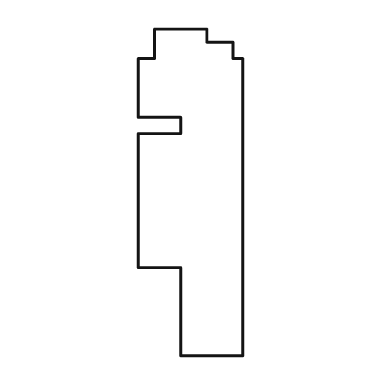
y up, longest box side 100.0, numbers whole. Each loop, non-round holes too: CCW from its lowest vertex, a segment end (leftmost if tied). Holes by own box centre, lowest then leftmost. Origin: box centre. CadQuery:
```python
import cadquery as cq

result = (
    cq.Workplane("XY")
    .moveTo(-3.0, -50.0)
    .lineTo(16.0, -50.0)
    .lineTo(16.0, 41.0)
    .lineTo(13.0, 41.0)
    .lineTo(13.0, 46.0)
    .lineTo(5.0, 46.0)
    .lineTo(5.0, 50.0)
    .lineTo(-11.0, 50.0)
    .lineTo(-11.0, 41.0)
    .lineTo(-16.0, 41.0)
    .lineTo(-16.0, 23.0)
    .lineTo(-3.0, 23.0)
    .lineTo(-3.0, 18.0)
    .lineTo(-16.0, 18.0)
    .lineTo(-16.0, -23.0)
    .lineTo(-3.0, -23.0)
    .close()
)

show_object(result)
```